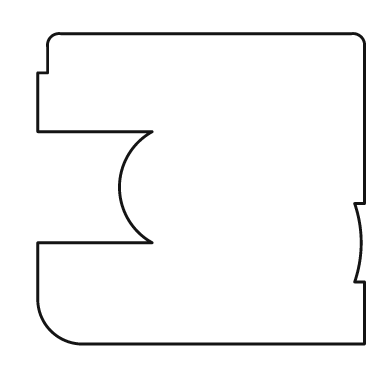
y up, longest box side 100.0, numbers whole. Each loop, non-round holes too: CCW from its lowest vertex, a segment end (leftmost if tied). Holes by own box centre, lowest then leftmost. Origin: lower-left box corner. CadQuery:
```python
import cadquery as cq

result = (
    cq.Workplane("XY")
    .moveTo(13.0, 0.0)
    .lineTo(100.0, 0.0)
    .lineTo(100.0, 19.0)
    .lineTo(97.0, 19.0)
    .threePointArc((99.0, 31.0), (97.0, 43.0))
    .lineTo(100.0, 43.0)
    .lineTo(100.0, 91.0)
    .threePointArc((99.0, 94.0), (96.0, 95.0))
    .lineTo(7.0, 95.0)
    .threePointArc((4.0, 94.0), (3.0, 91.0))
    .lineTo(3.0, 83.0)
    .lineTo(0.0, 83.0)
    .lineTo(0.0, 65.0)
    .lineTo(35.0, 65.0)
    .threePointArc((25.0, 48.0), (35.0, 31.0))
    .lineTo(0.0, 31.0)
    .lineTo(0.0, 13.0)
    .threePointArc((4.0, 4.0), (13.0, 0.0))
    .close()
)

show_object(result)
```